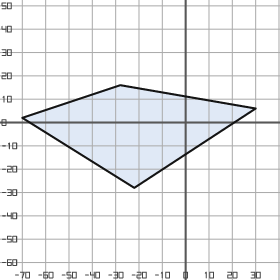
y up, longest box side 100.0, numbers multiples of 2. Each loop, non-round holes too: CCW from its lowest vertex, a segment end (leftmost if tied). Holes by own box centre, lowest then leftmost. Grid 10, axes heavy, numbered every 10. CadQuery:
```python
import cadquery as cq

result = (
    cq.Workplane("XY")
    .moveTo(-22.0, -28.0)
    .lineTo(30.0, 6.0)
    .lineTo(-28.0, 16.0)
    .lineTo(-70.0, 2.0)
    .close()
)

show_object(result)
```